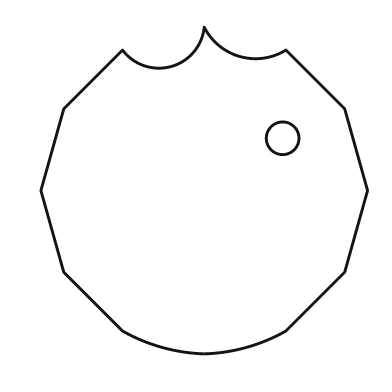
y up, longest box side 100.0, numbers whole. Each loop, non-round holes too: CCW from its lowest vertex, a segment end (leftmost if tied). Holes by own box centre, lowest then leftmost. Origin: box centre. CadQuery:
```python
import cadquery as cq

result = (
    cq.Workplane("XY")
    .moveTo(0.0, -50.0)
    .threePointArc((13.0, -48.0), (25.0, -43.0))
    .lineTo(43.0, -25.0)
    .lineTo(50.0, 0.0)
    .lineTo(43.0, 25.0)
    .lineTo(25.0, 43.0)
    .threePointArc((11.0, 41.0), (0.0, 50.0))
    .threePointArc((-10.0, 38.0), (-25.0, 43.0))
    .lineTo(-43.0, 25.0)
    .lineTo(-50.0, 0.0)
    .lineTo(-43.0, -25.0)
    .lineTo(-25.0, -43.0)
    .threePointArc((-13.0, -48.0), (0.0, -50.0))
    .close()
    .moveTo(24.0, 16.0)
    .circle(5.0)
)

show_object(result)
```